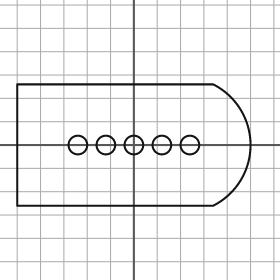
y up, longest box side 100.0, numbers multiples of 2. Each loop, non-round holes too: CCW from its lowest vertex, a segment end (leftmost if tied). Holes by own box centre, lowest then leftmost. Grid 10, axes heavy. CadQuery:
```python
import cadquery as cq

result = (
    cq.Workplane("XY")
    .moveTo(-50.0, -26.0)
    .lineTo(34.0, -26.0)
    .threePointArc((50.0, 0.0), (34.0, 26.0))
    .lineTo(-50.0, 26.0)
    .close()
    .moveTo(-24.0, 0.0)
    .circle(4.0)
    .moveTo(-12.0, 0.0)
    .circle(4.0)
    .moveTo(0.0, 0.0)
    .circle(4.0)
    .moveTo(12.0, 0.0)
    .circle(4.0)
    .moveTo(24.0, 0.0)
    .circle(4.0)
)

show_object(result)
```